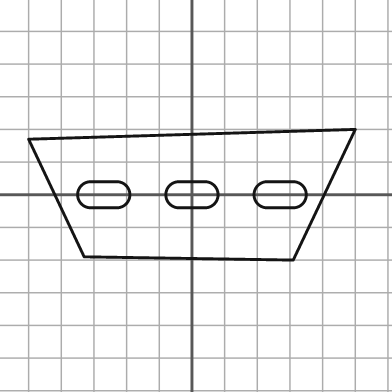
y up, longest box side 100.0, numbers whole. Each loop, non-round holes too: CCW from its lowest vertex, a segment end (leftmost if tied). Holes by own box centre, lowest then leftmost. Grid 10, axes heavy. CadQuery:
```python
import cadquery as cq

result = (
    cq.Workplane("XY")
    .moveTo(31.0, -20.0)
    .lineTo(50.0, 20.0)
    .lineTo(-50.0, 17.0)
    .lineTo(-33.0, -19.0)
    .close()
    .moveTo(-31.0, -4.0)
    .lineTo(-23.0, -4.0)
    .threePointArc((-19.0, 0.0), (-23.0, 4.0))
    .lineTo(-31.0, 4.0)
    .threePointArc((-35.0, 0.0), (-31.0, -4.0))
    .close()
    .moveTo(-4.0, -4.0)
    .lineTo(4.0, -4.0)
    .threePointArc((8.0, 0.0), (4.0, 4.0))
    .lineTo(-4.0, 4.0)
    .threePointArc((-8.0, 0.0), (-4.0, -4.0))
    .close()
    .moveTo(23.0, -4.0)
    .lineTo(31.0, -4.0)
    .threePointArc((35.0, 0.0), (31.0, 4.0))
    .lineTo(23.0, 4.0)
    .threePointArc((19.0, 0.0), (23.0, -4.0))
    .close()
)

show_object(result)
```